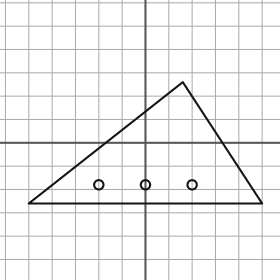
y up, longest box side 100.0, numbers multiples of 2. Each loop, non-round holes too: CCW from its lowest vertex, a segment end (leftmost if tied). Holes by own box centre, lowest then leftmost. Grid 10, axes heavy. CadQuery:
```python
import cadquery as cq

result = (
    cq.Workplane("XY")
    .moveTo(-50.0, -26.0)
    .lineTo(50.0, -26.0)
    .lineTo(16.0, 26.0)
    .close()
    .moveTo(-20.0, -18.0)
    .circle(2.0)
    .moveTo(0.0, -18.0)
    .circle(2.0)
    .moveTo(20.0, -18.0)
    .circle(2.0)
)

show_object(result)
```